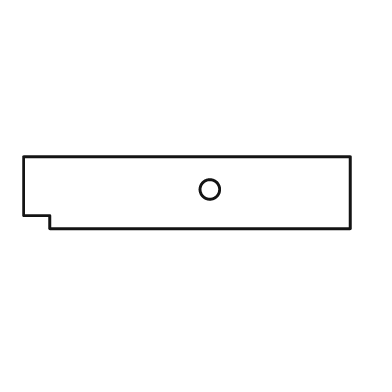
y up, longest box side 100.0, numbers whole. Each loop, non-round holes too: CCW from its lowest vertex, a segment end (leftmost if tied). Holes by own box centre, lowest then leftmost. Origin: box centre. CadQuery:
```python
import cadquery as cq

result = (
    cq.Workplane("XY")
    .moveTo(-42.0, -11.0)
    .lineTo(50.0, -11.0)
    .lineTo(50.0, 11.0)
    .lineTo(-50.0, 11.0)
    .lineTo(-50.0, -7.0)
    .lineTo(-42.0, -7.0)
    .close()
    .moveTo(7.0, 1.0)
    .circle(3.0)
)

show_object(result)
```